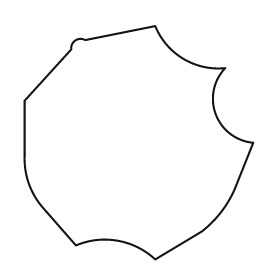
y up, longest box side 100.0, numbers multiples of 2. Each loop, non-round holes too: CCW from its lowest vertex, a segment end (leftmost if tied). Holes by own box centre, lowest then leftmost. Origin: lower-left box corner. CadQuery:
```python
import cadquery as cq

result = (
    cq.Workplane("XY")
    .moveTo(56.0, 0.0)
    .lineTo(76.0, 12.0)
    .threePointArc((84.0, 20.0), (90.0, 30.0))
    .lineTo(98.0, 50.0)
    .threePointArc((82.0, 62.0), (86.0, 82.0))
    .threePointArc((68.0, 86.0), (56.0, 100.0))
    .lineTo(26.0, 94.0)
    .threePointArc((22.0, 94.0), (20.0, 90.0))
    .lineTo(0.0, 68.0)
    .lineTo(0.0, 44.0)
    .threePointArc((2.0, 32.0), (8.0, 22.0))
    .lineTo(22.0, 6.0)
    .threePointArc((40.0, 8.0), (56.0, 0.0))
    .close()
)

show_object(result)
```